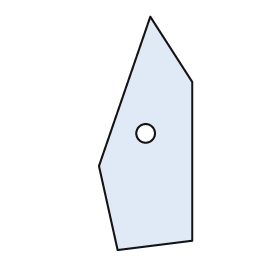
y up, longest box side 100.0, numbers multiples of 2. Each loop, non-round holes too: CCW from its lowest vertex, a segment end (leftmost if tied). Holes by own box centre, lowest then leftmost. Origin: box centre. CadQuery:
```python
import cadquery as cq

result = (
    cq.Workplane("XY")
    .moveTo(-12.0, -50.0)
    .lineTo(20.0, -46.0)
    .lineTo(20.0, 22.0)
    .lineTo(2.0, 50.0)
    .lineTo(-20.0, -14.0)
    .close()
    .moveTo(0.0, 0.0)
    .circle(4.0)
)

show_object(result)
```